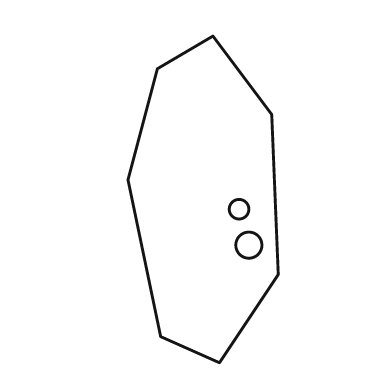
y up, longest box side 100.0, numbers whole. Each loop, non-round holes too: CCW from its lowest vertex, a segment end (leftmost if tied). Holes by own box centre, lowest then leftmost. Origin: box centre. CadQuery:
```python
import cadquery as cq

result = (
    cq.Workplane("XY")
    .moveTo(5.0, -50.0)
    .lineTo(23.0, -23.0)
    .lineTo(21.0, 26.0)
    .lineTo(3.0, 50.0)
    .lineTo(-14.0, 40.0)
    .lineTo(-23.0, 6.0)
    .lineTo(-13.0, -42.0)
    .close()
    .moveTo(14.0, -14.0)
    .circle(4.0)
    .moveTo(11.0, -3.0)
    .circle(3.0)
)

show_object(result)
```